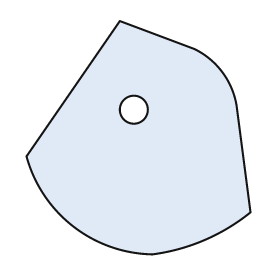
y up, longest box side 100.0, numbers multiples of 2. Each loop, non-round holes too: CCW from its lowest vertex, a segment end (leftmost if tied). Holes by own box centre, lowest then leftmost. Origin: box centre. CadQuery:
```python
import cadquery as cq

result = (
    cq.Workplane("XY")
    .moveTo(6.0, -50.0)
    .threePointArc((28.0, -44.0), (48.0, -32.0))
    .lineTo(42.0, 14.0)
    .threePointArc((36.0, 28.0), (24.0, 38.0))
    .lineTo(-8.0, 50.0)
    .lineTo(-48.0, -8.0)
    .threePointArc((-28.0, -38.0), (6.0, -50.0))
    .close()
    .moveTo(-2.0, 12.0)
    .circle(6.0)
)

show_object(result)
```